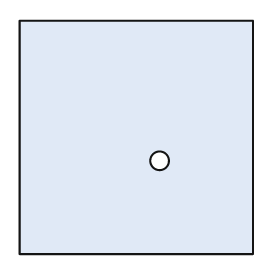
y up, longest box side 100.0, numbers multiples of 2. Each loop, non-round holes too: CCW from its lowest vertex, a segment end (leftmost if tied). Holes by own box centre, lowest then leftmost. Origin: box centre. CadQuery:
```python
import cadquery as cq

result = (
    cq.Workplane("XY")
    .moveTo(-50.0, -50.0)
    .lineTo(50.0, -50.0)
    .lineTo(50.0, 50.0)
    .lineTo(-50.0, 50.0)
    .close()
    .moveTo(10.0, -10.0)
    .circle(4.0)
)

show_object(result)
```